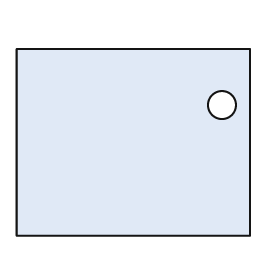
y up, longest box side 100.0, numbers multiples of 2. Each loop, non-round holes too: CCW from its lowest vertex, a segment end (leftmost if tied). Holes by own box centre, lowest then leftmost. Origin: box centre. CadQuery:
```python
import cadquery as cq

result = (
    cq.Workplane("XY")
    .moveTo(-50.0, -40.0)
    .lineTo(50.0, -40.0)
    .lineTo(50.0, 40.0)
    .lineTo(-50.0, 40.0)
    .close()
    .moveTo(38.0, 16.0)
    .circle(6.0)
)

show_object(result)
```